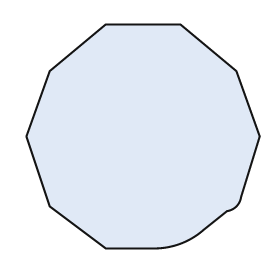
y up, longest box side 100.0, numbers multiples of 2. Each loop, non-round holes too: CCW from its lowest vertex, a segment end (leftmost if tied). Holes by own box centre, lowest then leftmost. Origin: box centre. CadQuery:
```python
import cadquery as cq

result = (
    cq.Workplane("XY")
    .moveTo(-16.0, -48.0)
    .lineTo(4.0, -48.0)
    .threePointArc((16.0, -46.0), (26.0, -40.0))
    .lineTo(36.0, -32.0)
    .threePointArc((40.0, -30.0), (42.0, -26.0))
    .lineTo(50.0, 0.0)
    .lineTo(40.0, 28.0)
    .lineTo(16.0, 48.0)
    .lineTo(-16.0, 48.0)
    .lineTo(-40.0, 28.0)
    .lineTo(-50.0, 0.0)
    .lineTo(-40.0, -30.0)
    .close()
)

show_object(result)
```